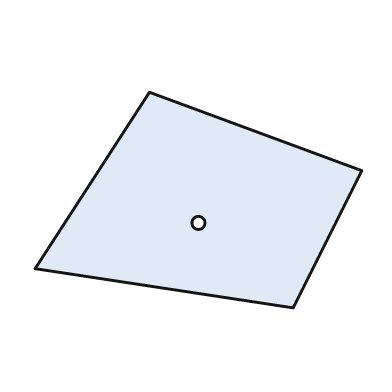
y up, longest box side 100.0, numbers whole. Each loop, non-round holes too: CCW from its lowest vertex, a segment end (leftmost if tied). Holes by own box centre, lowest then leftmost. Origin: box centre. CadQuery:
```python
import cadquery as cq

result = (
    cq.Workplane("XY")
    .moveTo(29.0, -33.0)
    .lineTo(50.0, 9.0)
    .lineTo(-15.0, 33.0)
    .lineTo(-50.0, -21.0)
    .close()
    .moveTo(0.0, -7.0)
    .circle(2.0)
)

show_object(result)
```